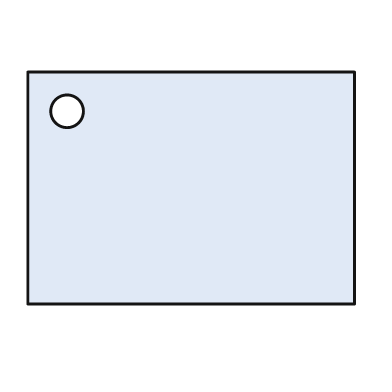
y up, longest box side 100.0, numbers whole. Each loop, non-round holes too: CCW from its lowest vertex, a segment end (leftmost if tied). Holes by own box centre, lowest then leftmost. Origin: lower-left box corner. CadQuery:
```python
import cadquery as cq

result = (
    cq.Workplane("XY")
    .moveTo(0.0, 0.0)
    .lineTo(100.0, 0.0)
    .lineTo(100.0, 71.0)
    .lineTo(0.0, 71.0)
    .close()
    .moveTo(12.0, 59.0)
    .circle(5.0)
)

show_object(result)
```